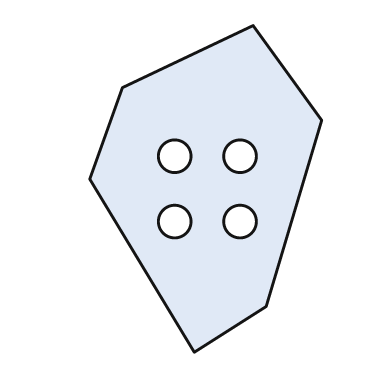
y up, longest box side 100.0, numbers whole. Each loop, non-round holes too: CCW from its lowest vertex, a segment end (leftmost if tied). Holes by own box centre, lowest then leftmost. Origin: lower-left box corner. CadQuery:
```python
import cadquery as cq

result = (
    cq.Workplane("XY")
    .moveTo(32.0, 0.0)
    .lineTo(54.0, 14.0)
    .lineTo(71.0, 71.0)
    .lineTo(50.0, 100.0)
    .lineTo(10.0, 81.0)
    .lineTo(0.0, 53.0)
    .close()
    .moveTo(26.0, 40.0)
    .circle(5.0)
    .moveTo(46.0, 40.0)
    .circle(5.0)
    .moveTo(26.0, 60.0)
    .circle(5.0)
    .moveTo(46.0, 60.0)
    .circle(5.0)
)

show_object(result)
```